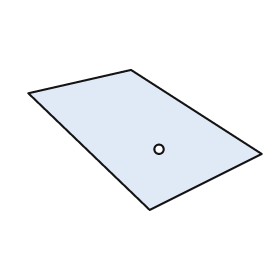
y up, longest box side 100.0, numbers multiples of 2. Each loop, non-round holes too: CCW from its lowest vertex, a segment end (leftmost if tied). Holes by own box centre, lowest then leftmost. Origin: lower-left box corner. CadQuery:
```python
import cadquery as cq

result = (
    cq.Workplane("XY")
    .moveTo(52.0, 0.0)
    .lineTo(100.0, 24.0)
    .lineTo(44.0, 60.0)
    .lineTo(0.0, 50.0)
    .close()
    .moveTo(56.0, 26.0)
    .circle(2.0)
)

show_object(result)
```